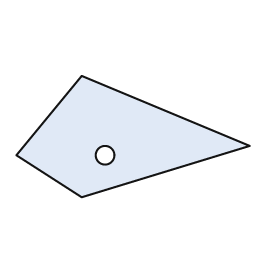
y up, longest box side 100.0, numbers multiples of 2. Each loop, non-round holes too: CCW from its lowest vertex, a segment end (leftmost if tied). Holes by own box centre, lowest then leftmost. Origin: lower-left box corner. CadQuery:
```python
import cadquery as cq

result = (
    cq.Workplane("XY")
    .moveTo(28.0, 0.0)
    .lineTo(100.0, 22.0)
    .lineTo(28.0, 52.0)
    .lineTo(0.0, 18.0)
    .close()
    .moveTo(38.0, 18.0)
    .circle(4.0)
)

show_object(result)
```